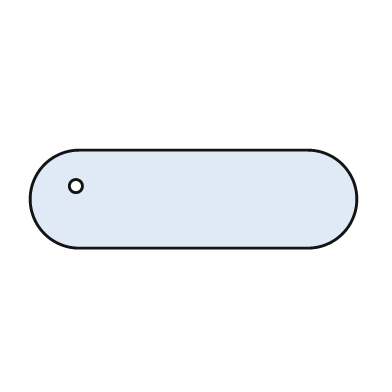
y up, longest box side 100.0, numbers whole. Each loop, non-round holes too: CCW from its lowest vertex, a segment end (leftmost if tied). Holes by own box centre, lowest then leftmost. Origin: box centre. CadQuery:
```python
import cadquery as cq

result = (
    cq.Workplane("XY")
    .moveTo(-35.0, -15.0)
    .lineTo(35.0, -15.0)
    .threePointArc((50.0, 0.0), (35.0, 15.0))
    .lineTo(-35.0, 15.0)
    .threePointArc((-50.0, 0.0), (-35.0, -15.0))
    .close()
    .moveTo(-36.0, 4.0)
    .circle(2.0)
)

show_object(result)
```